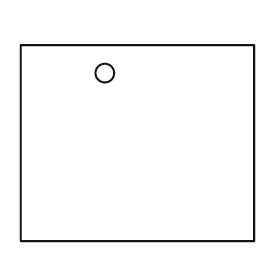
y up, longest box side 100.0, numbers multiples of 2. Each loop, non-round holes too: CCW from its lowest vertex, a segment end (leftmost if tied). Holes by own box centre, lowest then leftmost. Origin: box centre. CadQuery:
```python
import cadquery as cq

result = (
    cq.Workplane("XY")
    .moveTo(-50.0, -42.0)
    .lineTo(50.0, -42.0)
    .lineTo(50.0, 42.0)
    .lineTo(-50.0, 42.0)
    .close()
    .moveTo(-14.0, 30.0)
    .circle(4.0)
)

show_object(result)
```